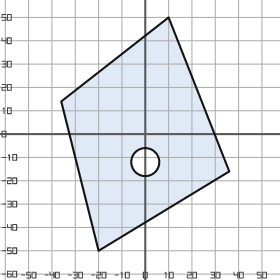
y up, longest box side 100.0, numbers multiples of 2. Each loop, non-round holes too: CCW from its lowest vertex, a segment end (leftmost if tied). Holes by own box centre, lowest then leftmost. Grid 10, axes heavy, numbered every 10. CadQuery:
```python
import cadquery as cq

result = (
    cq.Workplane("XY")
    .moveTo(-20.0, -50.0)
    .lineTo(36.0, -16.0)
    .lineTo(10.0, 50.0)
    .lineTo(-36.0, 14.0)
    .close()
    .moveTo(0.0, -12.0)
    .circle(6.0)
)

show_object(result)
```